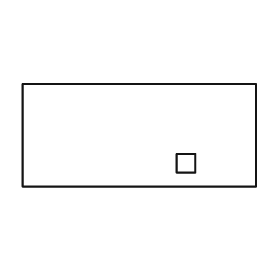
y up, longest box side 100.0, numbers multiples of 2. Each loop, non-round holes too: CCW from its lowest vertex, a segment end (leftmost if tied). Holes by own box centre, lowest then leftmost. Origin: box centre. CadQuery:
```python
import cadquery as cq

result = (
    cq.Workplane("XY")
    .moveTo(-50.0, -22.0)
    .lineTo(50.0, -22.0)
    .lineTo(50.0, 22.0)
    .lineTo(-50.0, 22.0)
    .close()
    .moveTo(16.0, -16.0)
    .lineTo(24.0, -16.0)
    .lineTo(24.0, -8.0)
    .lineTo(16.0, -8.0)
    .close()
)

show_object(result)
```